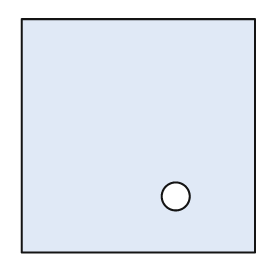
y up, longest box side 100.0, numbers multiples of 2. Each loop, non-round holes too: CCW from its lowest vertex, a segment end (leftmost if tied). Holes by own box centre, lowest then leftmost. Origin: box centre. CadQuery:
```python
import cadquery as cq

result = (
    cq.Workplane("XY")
    .moveTo(-50.0, -50.0)
    .lineTo(50.0, -50.0)
    .lineTo(50.0, 50.0)
    .lineTo(-50.0, 50.0)
    .close()
    .moveTo(16.0, -26.0)
    .circle(6.0)
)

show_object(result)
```